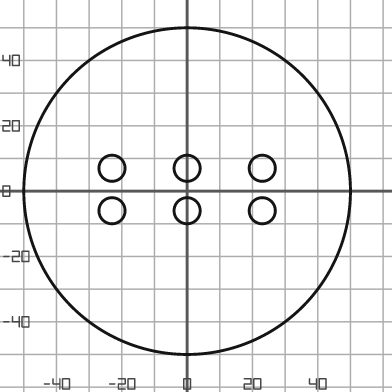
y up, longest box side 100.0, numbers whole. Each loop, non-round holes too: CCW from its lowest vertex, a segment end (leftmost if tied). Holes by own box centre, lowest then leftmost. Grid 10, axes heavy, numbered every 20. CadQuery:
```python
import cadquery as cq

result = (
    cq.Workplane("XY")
    .moveTo(0.0, 0.0)
    .circle(50.0)
    .moveTo(-23.0, -6.0)
    .circle(4.0)
    .moveTo(0.0, -6.0)
    .circle(4.0)
    .moveTo(23.0, -6.0)
    .circle(4.0)
    .moveTo(-23.0, 7.0)
    .circle(4.0)
    .moveTo(0.0, 7.0)
    .circle(4.0)
    .moveTo(23.0, 7.0)
    .circle(4.0)
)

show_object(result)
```